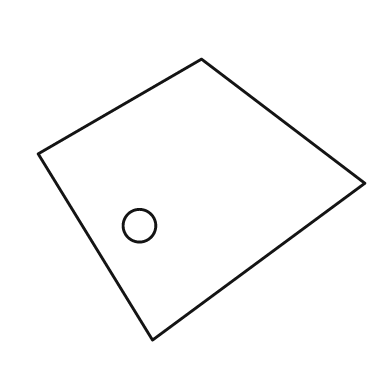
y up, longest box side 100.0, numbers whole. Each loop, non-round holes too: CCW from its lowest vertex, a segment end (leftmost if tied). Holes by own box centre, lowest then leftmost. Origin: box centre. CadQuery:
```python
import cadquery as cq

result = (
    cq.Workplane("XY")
    .moveTo(-15.0, -43.0)
    .lineTo(50.0, 5.0)
    .lineTo(0.0, 43.0)
    .lineTo(-50.0, 14.0)
    .close()
    .moveTo(-19.0, -8.0)
    .circle(5.0)
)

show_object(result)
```